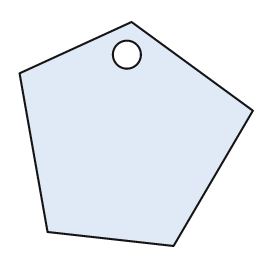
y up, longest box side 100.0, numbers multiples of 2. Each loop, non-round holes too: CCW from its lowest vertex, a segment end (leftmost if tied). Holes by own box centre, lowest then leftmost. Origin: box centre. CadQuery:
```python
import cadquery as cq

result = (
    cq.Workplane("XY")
    .moveTo(16.0, -48.0)
    .lineTo(50.0, 10.0)
    .lineTo(-2.0, 48.0)
    .lineTo(-50.0, 26.0)
    .lineTo(-38.0, -42.0)
    .close()
    .moveTo(-4.0, 34.0)
    .circle(6.0)
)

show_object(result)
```